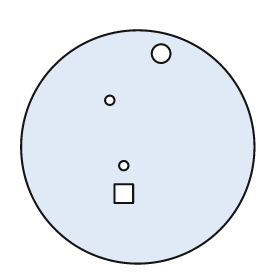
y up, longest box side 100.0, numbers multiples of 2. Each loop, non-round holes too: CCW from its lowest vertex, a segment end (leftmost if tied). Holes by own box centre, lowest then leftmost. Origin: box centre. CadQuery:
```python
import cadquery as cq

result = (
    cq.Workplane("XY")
    .moveTo(0.0, 0.0)
    .circle(50.0)
    .moveTo(-10.0, -24.0)
    .lineTo(-2.0, -24.0)
    .lineTo(-2.0, -16.0)
    .lineTo(-10.0, -16.0)
    .close()
    .moveTo(-6.0, -8.0)
    .circle(2.0)
    .moveTo(-12.0, 20.0)
    .circle(2.0)
    .moveTo(10.0, 40.0)
    .circle(4.0)
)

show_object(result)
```